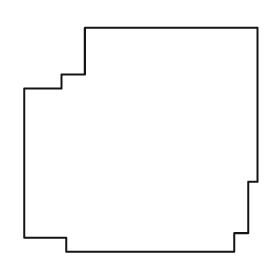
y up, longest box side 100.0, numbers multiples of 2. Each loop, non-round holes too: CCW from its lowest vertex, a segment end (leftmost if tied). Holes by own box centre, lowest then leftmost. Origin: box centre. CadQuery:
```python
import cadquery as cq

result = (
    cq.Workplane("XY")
    .moveTo(-32.0, -48.0)
    .lineTo(40.0, -48.0)
    .lineTo(40.0, -40.0)
    .lineTo(46.0, -40.0)
    .lineTo(46.0, -18.0)
    .lineTo(50.0, -18.0)
    .lineTo(50.0, 48.0)
    .lineTo(-24.0, 48.0)
    .lineTo(-24.0, 28.0)
    .lineTo(-34.0, 28.0)
    .lineTo(-34.0, 22.0)
    .lineTo(-50.0, 22.0)
    .lineTo(-50.0, -42.0)
    .lineTo(-32.0, -42.0)
    .close()
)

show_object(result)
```